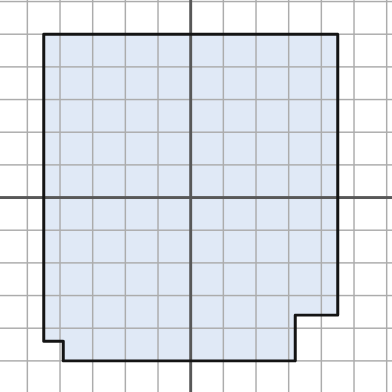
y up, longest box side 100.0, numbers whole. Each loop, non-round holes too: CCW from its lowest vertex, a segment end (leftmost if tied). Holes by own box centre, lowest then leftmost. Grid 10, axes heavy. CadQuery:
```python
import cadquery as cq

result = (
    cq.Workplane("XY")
    .moveTo(-39.0, -50.0)
    .lineTo(32.0, -50.0)
    .lineTo(32.0, -36.0)
    .lineTo(45.0, -36.0)
    .lineTo(45.0, 50.0)
    .lineTo(-45.0, 50.0)
    .lineTo(-45.0, -44.0)
    .lineTo(-39.0, -44.0)
    .close()
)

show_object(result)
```